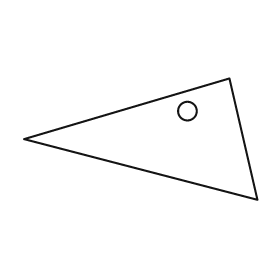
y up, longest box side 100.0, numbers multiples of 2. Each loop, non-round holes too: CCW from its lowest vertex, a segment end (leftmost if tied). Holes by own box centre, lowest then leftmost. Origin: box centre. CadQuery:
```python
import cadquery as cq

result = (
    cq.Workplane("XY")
    .moveTo(50.0, -26.0)
    .lineTo(38.0, 26.0)
    .lineTo(-50.0, 0.0)
    .close()
    .moveTo(20.0, 12.0)
    .circle(4.0)
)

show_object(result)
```